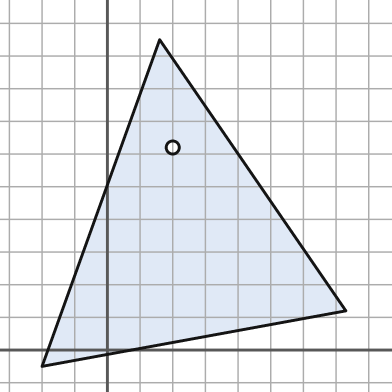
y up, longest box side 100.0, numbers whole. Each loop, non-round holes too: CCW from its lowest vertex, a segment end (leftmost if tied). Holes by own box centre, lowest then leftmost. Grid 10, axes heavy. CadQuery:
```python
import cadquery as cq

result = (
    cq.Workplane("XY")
    .moveTo(-20.0, -5.0)
    .lineTo(73.0, 12.0)
    .lineTo(16.0, 95.0)
    .close()
    .moveTo(20.0, 62.0)
    .circle(2.0)
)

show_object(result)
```